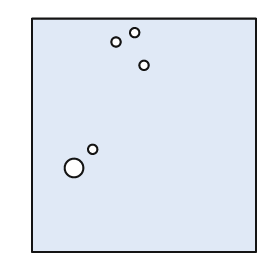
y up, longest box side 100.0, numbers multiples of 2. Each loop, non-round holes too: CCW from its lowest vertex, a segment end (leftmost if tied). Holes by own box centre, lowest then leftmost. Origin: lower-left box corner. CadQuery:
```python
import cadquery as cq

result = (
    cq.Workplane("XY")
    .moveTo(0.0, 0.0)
    .lineTo(96.0, 0.0)
    .lineTo(96.0, 100.0)
    .lineTo(0.0, 100.0)
    .close()
    .moveTo(18.0, 36.0)
    .circle(4.0)
    .moveTo(26.0, 44.0)
    .circle(2.0)
    .moveTo(48.0, 80.0)
    .circle(2.0)
    .moveTo(36.0, 90.0)
    .circle(2.0)
    .moveTo(44.0, 94.0)
    .circle(2.0)
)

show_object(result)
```